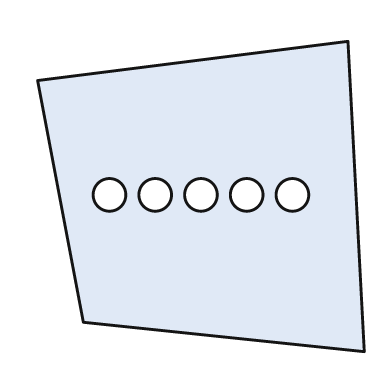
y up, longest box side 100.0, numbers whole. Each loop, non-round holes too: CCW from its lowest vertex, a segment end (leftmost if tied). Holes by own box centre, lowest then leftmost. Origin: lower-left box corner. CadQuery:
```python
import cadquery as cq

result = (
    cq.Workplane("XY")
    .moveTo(100.0, 0.0)
    .lineTo(95.0, 95.0)
    .lineTo(0.0, 83.0)
    .lineTo(14.0, 9.0)
    .close()
    .moveTo(22.0, 48.0)
    .circle(5.0)
    .moveTo(36.0, 48.0)
    .circle(5.0)
    .moveTo(50.0, 48.0)
    .circle(5.0)
    .moveTo(64.0, 48.0)
    .circle(5.0)
    .moveTo(78.0, 48.0)
    .circle(5.0)
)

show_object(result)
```